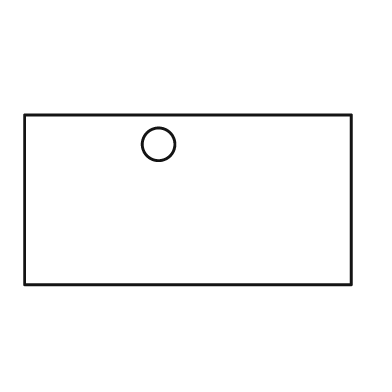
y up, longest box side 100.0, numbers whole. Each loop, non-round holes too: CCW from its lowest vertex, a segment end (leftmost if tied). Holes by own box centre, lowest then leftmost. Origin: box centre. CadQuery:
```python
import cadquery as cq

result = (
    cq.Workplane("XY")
    .moveTo(-50.0, -26.0)
    .lineTo(50.0, -26.0)
    .lineTo(50.0, 26.0)
    .lineTo(-50.0, 26.0)
    .close()
    .moveTo(-9.0, 17.0)
    .circle(5.0)
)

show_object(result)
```